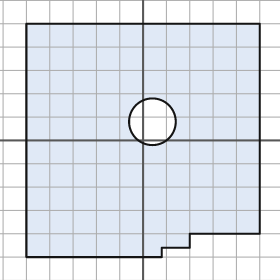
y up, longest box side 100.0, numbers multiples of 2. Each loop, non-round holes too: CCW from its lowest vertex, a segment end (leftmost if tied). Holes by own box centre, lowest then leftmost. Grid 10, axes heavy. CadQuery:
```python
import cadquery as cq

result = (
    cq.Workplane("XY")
    .moveTo(-50.0, -50.0)
    .lineTo(8.0, -50.0)
    .lineTo(8.0, -46.0)
    .lineTo(20.0, -46.0)
    .lineTo(20.0, -40.0)
    .lineTo(50.0, -40.0)
    .lineTo(50.0, 50.0)
    .lineTo(-50.0, 50.0)
    .close()
    .moveTo(4.0, 8.0)
    .circle(10.0)
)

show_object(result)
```